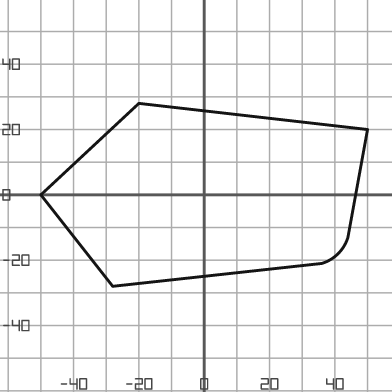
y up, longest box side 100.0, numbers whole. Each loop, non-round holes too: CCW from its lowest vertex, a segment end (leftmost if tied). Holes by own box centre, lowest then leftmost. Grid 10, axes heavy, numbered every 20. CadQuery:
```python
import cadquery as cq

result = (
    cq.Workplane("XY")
    .moveTo(-28.0, -28.0)
    .lineTo(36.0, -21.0)
    .threePointArc((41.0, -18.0), (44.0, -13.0))
    .lineTo(50.0, 20.0)
    .lineTo(-20.0, 28.0)
    .lineTo(-50.0, 0.0)
    .close()
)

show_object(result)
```